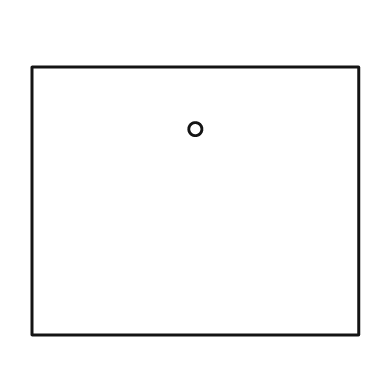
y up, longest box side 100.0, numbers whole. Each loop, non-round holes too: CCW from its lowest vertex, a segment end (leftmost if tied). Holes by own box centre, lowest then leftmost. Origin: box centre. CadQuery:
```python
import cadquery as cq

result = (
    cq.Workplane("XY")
    .moveTo(-50.0, -41.0)
    .lineTo(50.0, -41.0)
    .lineTo(50.0, 41.0)
    .lineTo(-50.0, 41.0)
    .close()
    .moveTo(0.0, 22.0)
    .circle(2.0)
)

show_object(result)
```